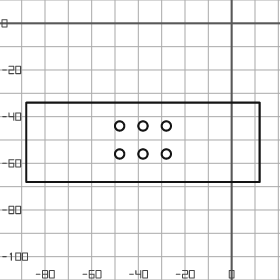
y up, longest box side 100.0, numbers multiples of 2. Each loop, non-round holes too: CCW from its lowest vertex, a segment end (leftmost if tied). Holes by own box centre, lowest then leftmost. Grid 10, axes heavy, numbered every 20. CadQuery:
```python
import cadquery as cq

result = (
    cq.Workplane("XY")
    .moveTo(-88.0, -68.0)
    .lineTo(12.0, -68.0)
    .lineTo(12.0, -34.0)
    .lineTo(-88.0, -34.0)
    .close()
    .moveTo(-48.0, -56.0)
    .circle(2.0)
    .moveTo(-38.0, -56.0)
    .circle(2.0)
    .moveTo(-28.0, -56.0)
    .circle(2.0)
    .moveTo(-48.0, -44.0)
    .circle(2.0)
    .moveTo(-38.0, -44.0)
    .circle(2.0)
    .moveTo(-28.0, -44.0)
    .circle(2.0)
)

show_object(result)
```